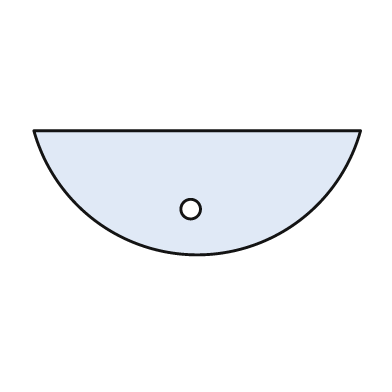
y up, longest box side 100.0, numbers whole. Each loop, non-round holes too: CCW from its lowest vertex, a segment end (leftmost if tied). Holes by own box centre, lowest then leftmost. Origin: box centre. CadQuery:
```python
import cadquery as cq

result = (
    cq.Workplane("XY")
    .moveTo(-50.0, 19.0)
    .threePointArc((0.0, -19.0), (50.0, 19.0))
    .close()
    .moveTo(-2.0, -5.0)
    .circle(3.0)
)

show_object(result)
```